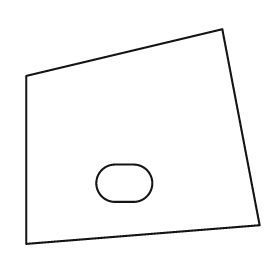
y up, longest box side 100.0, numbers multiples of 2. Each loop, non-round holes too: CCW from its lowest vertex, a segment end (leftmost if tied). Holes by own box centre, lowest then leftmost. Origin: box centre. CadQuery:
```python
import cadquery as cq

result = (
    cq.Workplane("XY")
    .moveTo(-50.0, -46.0)
    .lineTo(50.0, -38.0)
    .lineTo(34.0, 46.0)
    .lineTo(-50.0, 26.0)
    .close()
    .moveTo(-12.0, -28.0)
    .lineTo(-4.0, -28.0)
    .threePointArc((4.0, -20.0), (-4.0, -12.0))
    .lineTo(-12.0, -12.0)
    .threePointArc((-20.0, -20.0), (-12.0, -28.0))
    .close()
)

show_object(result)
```